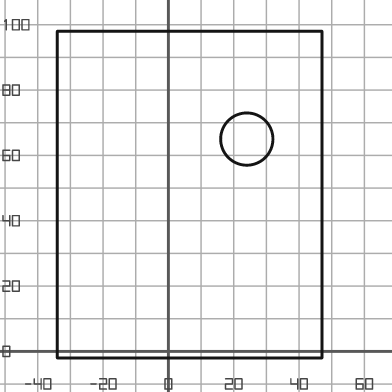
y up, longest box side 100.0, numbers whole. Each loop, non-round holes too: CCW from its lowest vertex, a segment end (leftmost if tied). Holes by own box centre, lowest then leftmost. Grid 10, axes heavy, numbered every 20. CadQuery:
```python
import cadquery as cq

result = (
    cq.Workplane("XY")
    .moveTo(-34.0, -2.0)
    .lineTo(47.0, -2.0)
    .lineTo(47.0, 98.0)
    .lineTo(-34.0, 98.0)
    .close()
    .moveTo(24.0, 65.0)
    .circle(8.0)
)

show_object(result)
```